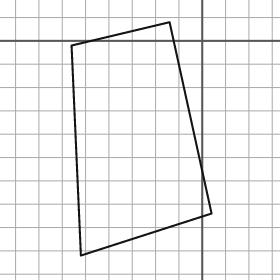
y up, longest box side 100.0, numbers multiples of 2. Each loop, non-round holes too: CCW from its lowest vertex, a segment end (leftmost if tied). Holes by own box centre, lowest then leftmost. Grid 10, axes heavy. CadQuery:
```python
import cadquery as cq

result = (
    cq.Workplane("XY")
    .moveTo(-52.0, -92.0)
    .lineTo(4.0, -74.0)
    .lineTo(-14.0, 8.0)
    .lineTo(-56.0, -2.0)
    .close()
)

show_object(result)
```